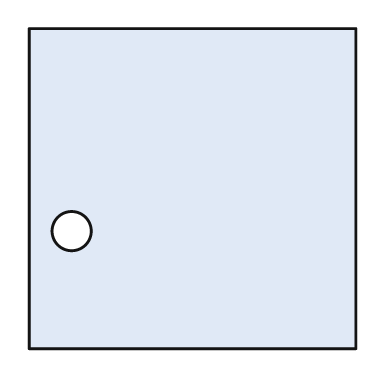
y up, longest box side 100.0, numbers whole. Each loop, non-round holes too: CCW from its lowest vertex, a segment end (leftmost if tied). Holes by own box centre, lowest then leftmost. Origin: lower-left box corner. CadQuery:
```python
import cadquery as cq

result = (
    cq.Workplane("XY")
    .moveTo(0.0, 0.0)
    .lineTo(100.0, 0.0)
    .lineTo(100.0, 98.0)
    .lineTo(0.0, 98.0)
    .close()
    .moveTo(13.0, 36.0)
    .circle(6.0)
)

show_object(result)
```